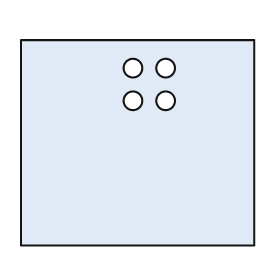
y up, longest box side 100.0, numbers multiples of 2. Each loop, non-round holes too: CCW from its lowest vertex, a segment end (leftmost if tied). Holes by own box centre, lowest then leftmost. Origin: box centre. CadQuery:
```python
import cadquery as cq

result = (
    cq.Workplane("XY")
    .moveTo(-50.0, -44.0)
    .lineTo(50.0, -44.0)
    .lineTo(50.0, 44.0)
    .lineTo(-50.0, 44.0)
    .close()
    .moveTo(-2.0, 18.0)
    .circle(4.0)
    .moveTo(12.0, 18.0)
    .circle(4.0)
    .moveTo(-2.0, 32.0)
    .circle(4.0)
    .moveTo(12.0, 32.0)
    .circle(4.0)
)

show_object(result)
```